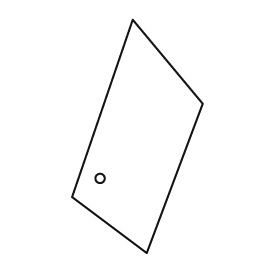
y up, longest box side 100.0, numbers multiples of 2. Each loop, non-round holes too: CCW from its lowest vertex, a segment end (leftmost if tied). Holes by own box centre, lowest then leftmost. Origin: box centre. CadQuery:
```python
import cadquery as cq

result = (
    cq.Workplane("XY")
    .moveTo(4.0, -50.0)
    .lineTo(28.0, 14.0)
    .lineTo(-2.0, 50.0)
    .lineTo(-28.0, -26.0)
    .close()
    .moveTo(-16.0, -18.0)
    .circle(2.0)
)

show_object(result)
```